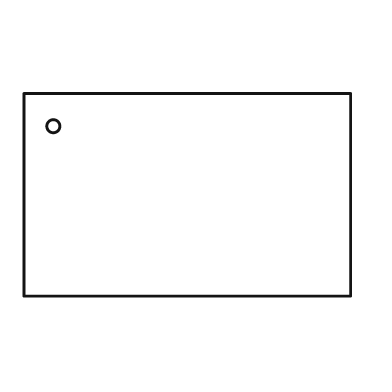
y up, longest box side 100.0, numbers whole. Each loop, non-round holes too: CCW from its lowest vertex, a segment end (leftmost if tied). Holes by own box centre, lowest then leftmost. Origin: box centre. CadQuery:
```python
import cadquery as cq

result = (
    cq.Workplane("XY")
    .moveTo(-50.0, -31.0)
    .lineTo(50.0, -31.0)
    .lineTo(50.0, 31.0)
    .lineTo(-50.0, 31.0)
    .close()
    .moveTo(-41.0, 21.0)
    .circle(2.0)
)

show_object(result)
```